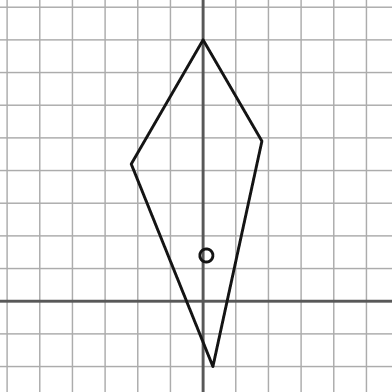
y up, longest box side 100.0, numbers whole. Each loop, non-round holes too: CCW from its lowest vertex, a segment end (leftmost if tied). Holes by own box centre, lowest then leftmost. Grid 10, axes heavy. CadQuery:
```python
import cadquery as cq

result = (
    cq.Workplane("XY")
    .moveTo(3.0, -20.0)
    .lineTo(18.0, 49.0)
    .lineTo(0.0, 80.0)
    .lineTo(-22.0, 42.0)
    .close()
    .moveTo(1.0, 14.0)
    .circle(2.0)
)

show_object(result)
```